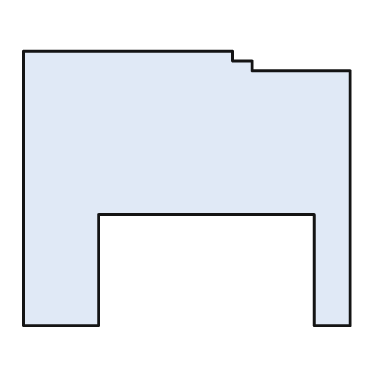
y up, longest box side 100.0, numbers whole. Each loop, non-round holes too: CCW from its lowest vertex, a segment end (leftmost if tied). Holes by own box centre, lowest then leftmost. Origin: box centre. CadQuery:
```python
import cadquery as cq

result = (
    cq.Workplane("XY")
    .moveTo(-50.0, -42.0)
    .lineTo(-27.0, -42.0)
    .lineTo(-27.0, -8.0)
    .lineTo(39.0, -8.0)
    .lineTo(39.0, -42.0)
    .lineTo(50.0, -42.0)
    .lineTo(50.0, 36.0)
    .lineTo(20.0, 36.0)
    .lineTo(20.0, 39.0)
    .lineTo(14.0, 39.0)
    .lineTo(14.0, 42.0)
    .lineTo(-50.0, 42.0)
    .close()
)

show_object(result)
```